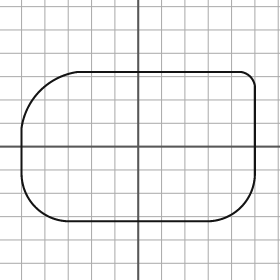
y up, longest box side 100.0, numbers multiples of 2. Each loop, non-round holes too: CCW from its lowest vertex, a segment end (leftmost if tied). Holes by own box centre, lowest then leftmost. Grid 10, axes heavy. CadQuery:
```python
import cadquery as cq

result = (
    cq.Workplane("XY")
    .moveTo(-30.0, -32.0)
    .lineTo(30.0, -32.0)
    .threePointArc((44.0, -26.0), (50.0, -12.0))
    .lineTo(50.0, 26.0)
    .threePointArc((48.0, 30.0), (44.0, 32.0))
    .lineTo(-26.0, 32.0)
    .threePointArc((-42.0, 24.0), (-50.0, 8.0))
    .lineTo(-50.0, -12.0)
    .threePointArc((-44.0, -26.0), (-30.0, -32.0))
    .close()
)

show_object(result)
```